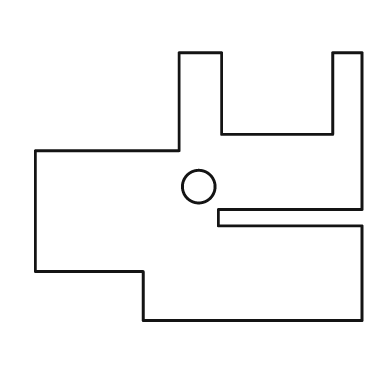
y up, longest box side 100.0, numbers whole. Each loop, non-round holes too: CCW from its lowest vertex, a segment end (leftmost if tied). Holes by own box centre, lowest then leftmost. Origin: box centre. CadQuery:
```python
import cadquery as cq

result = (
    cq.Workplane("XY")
    .moveTo(-17.0, -41.0)
    .lineTo(50.0, -41.0)
    .lineTo(50.0, -12.0)
    .lineTo(6.0, -12.0)
    .lineTo(6.0, -7.0)
    .lineTo(50.0, -7.0)
    .lineTo(50.0, 41.0)
    .lineTo(41.0, 41.0)
    .lineTo(41.0, 16.0)
    .lineTo(7.0, 16.0)
    .lineTo(7.0, 41.0)
    .lineTo(-6.0, 41.0)
    .lineTo(-6.0, 11.0)
    .lineTo(-50.0, 11.0)
    .lineTo(-50.0, -26.0)
    .lineTo(-17.0, -26.0)
    .close()
    .moveTo(0.0, 0.0)
    .circle(5.0)
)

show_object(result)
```